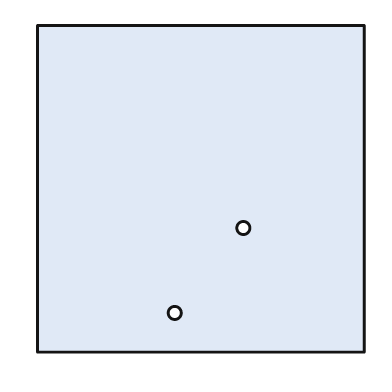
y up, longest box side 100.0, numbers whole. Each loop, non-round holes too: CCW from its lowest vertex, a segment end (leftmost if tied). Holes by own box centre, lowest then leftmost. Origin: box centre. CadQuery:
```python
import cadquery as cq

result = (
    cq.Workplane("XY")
    .moveTo(-50.0, -50.0)
    .lineTo(50.0, -50.0)
    .lineTo(50.0, 50.0)
    .lineTo(-50.0, 50.0)
    .close()
    .moveTo(-8.0, -38.0)
    .circle(2.0)
    .moveTo(13.0, -12.0)
    .circle(2.0)
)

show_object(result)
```